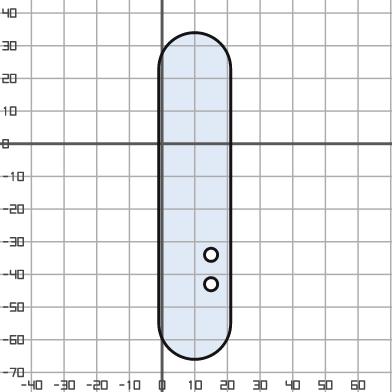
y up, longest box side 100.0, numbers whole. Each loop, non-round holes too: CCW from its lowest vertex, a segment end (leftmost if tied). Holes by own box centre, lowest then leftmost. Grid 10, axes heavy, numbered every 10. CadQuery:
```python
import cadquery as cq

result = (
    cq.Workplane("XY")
    .moveTo(-1.0, -55.0)
    .threePointArc((10.0, -66.0), (21.0, -55.0))
    .lineTo(21.0, 23.0)
    .threePointArc((10.0, 34.0), (-1.0, 23.0))
    .close()
    .moveTo(15.0, -43.0)
    .circle(2.0)
    .moveTo(15.0, -34.0)
    .circle(2.0)
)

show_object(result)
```